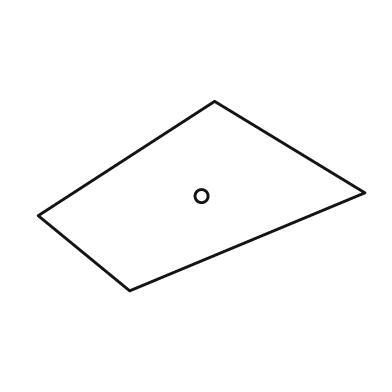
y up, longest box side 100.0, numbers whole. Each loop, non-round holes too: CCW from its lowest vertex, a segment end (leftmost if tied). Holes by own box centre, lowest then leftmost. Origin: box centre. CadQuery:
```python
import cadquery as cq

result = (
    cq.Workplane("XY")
    .moveTo(-22.0, -29.0)
    .lineTo(50.0, 1.0)
    .lineTo(4.0, 29.0)
    .lineTo(-50.0, -6.0)
    .close()
    .moveTo(0.0, 0.0)
    .circle(2.0)
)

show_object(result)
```